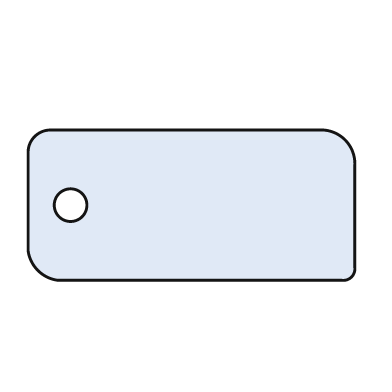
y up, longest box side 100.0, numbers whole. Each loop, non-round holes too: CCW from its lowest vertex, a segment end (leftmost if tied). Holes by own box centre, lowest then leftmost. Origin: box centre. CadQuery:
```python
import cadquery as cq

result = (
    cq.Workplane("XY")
    .moveTo(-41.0, -23.0)
    .lineTo(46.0, -23.0)
    .threePointArc((49.0, -22.0), (50.0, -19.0))
    .lineTo(50.0, 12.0)
    .threePointArc((47.0, 20.0), (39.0, 23.0))
    .lineTo(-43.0, 23.0)
    .threePointArc((-48.0, 21.0), (-50.0, 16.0))
    .lineTo(-50.0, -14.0)
    .threePointArc((-47.0, -20.0), (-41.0, -23.0))
    .close()
    .moveTo(-37.0, 0.0)
    .circle(5.0)
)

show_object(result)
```